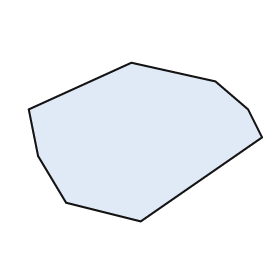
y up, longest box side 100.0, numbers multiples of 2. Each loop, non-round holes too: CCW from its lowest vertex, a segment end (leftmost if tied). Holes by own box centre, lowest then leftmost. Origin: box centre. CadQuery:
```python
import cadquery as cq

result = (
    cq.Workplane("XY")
    .moveTo(-2.0, -34.0)
    .lineTo(50.0, 2.0)
    .lineTo(44.0, 14.0)
    .lineTo(30.0, 26.0)
    .lineTo(-6.0, 34.0)
    .lineTo(-50.0, 14.0)
    .lineTo(-46.0, -6.0)
    .lineTo(-34.0, -26.0)
    .close()
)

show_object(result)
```